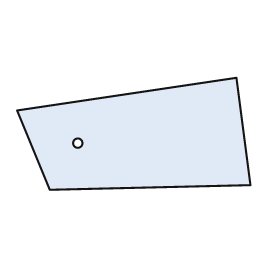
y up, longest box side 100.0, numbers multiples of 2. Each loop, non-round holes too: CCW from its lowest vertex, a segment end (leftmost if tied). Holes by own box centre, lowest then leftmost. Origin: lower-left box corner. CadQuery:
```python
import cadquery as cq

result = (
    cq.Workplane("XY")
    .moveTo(14.0, 0.0)
    .lineTo(100.0, 2.0)
    .lineTo(94.0, 48.0)
    .lineTo(0.0, 34.0)
    .close()
    .moveTo(26.0, 20.0)
    .circle(2.0)
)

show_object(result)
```